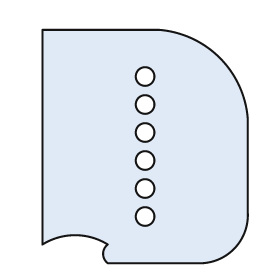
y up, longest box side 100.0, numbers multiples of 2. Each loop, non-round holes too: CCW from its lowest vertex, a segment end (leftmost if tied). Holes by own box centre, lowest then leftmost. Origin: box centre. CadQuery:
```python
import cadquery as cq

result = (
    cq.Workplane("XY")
    .moveTo(-16.0, -50.0)
    .lineTo(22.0, -50.0)
    .threePointArc((38.0, -44.0), (44.0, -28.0))
    .lineTo(44.0, 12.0)
    .threePointArc((32.0, 38.0), (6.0, 50.0))
    .lineTo(-44.0, 50.0)
    .lineTo(-44.0, -42.0)
    .threePointArc((-30.0, -38.0), (-16.0, -42.0))
    .threePointArc((-18.0, -46.0), (-16.0, -50.0))
    .close()
    .moveTo(0.0, -30.0)
    .circle(4.0)
    .moveTo(0.0, -18.0)
    .circle(4.0)
    .moveTo(0.0, -6.0)
    .circle(4.0)
    .moveTo(0.0, 6.0)
    .circle(4.0)
    .moveTo(0.0, 18.0)
    .circle(4.0)
    .moveTo(0.0, 30.0)
    .circle(4.0)
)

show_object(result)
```